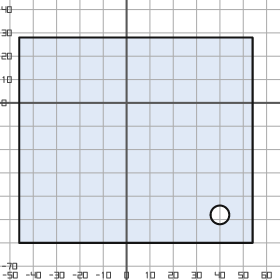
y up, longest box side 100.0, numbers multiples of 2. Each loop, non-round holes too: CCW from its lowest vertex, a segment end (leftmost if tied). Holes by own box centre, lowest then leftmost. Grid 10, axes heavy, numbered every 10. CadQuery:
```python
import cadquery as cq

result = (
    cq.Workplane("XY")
    .moveTo(-46.0, -60.0)
    .lineTo(54.0, -60.0)
    .lineTo(54.0, 28.0)
    .lineTo(-46.0, 28.0)
    .close()
    .moveTo(40.0, -48.0)
    .circle(4.0)
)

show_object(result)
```